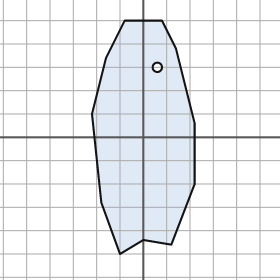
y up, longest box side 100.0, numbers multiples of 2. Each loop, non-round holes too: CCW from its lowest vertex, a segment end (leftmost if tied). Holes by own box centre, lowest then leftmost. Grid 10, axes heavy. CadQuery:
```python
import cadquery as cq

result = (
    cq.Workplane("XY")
    .moveTo(-10.0, -50.0)
    .lineTo(0.0, -44.0)
    .lineTo(12.0, -46.0)
    .lineTo(22.0, -20.0)
    .lineTo(22.0, 6.0)
    .lineTo(14.0, 38.0)
    .lineTo(8.0, 50.0)
    .lineTo(-8.0, 50.0)
    .lineTo(-16.0, 34.0)
    .lineTo(-22.0, 10.0)
    .lineTo(-18.0, -28.0)
    .close()
    .moveTo(6.0, 30.0)
    .circle(2.0)
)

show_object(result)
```